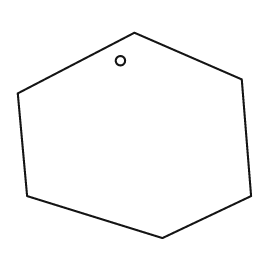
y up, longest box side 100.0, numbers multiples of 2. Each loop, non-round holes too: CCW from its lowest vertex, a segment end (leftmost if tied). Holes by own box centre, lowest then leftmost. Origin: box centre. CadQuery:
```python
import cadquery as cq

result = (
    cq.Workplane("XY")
    .moveTo(12.0, -44.0)
    .lineTo(50.0, -26.0)
    .lineTo(46.0, 24.0)
    .lineTo(0.0, 44.0)
    .lineTo(-50.0, 18.0)
    .lineTo(-46.0, -26.0)
    .close()
    .moveTo(-6.0, 32.0)
    .circle(2.0)
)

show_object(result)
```